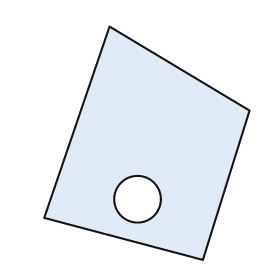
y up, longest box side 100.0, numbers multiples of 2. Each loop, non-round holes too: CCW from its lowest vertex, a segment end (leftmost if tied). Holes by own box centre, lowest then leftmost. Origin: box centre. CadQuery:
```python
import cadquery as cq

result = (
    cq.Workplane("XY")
    .moveTo(24.0, -50.0)
    .lineTo(44.0, 14.0)
    .lineTo(-16.0, 50.0)
    .lineTo(-44.0, -32.0)
    .close()
    .moveTo(-4.0, -24.0)
    .circle(10.0)
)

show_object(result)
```